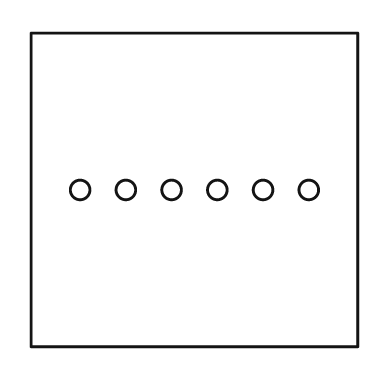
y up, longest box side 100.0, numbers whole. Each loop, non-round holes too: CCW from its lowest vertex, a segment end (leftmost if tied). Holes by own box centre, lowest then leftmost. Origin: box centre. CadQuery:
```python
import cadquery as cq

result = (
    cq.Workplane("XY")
    .moveTo(-50.0, -48.0)
    .lineTo(50.0, -48.0)
    .lineTo(50.0, 48.0)
    .lineTo(-50.0, 48.0)
    .close()
    .moveTo(-35.0, 0.0)
    .circle(3.0)
    .moveTo(-21.0, 0.0)
    .circle(3.0)
    .moveTo(-7.0, 0.0)
    .circle(3.0)
    .moveTo(7.0, 0.0)
    .circle(3.0)
    .moveTo(21.0, 0.0)
    .circle(3.0)
    .moveTo(35.0, 0.0)
    .circle(3.0)
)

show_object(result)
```